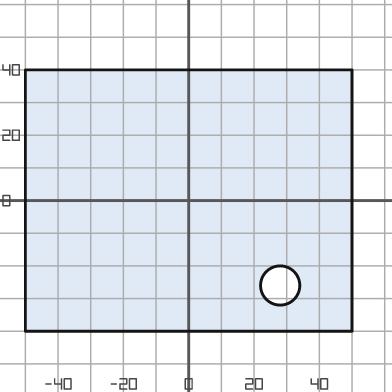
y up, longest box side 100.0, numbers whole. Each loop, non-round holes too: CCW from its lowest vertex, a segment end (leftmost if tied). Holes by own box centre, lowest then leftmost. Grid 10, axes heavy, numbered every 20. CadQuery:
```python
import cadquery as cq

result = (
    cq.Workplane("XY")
    .moveTo(-50.0, -40.0)
    .lineTo(50.0, -40.0)
    .lineTo(50.0, 40.0)
    .lineTo(-50.0, 40.0)
    .close()
    .moveTo(28.0, -26.0)
    .circle(6.0)
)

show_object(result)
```